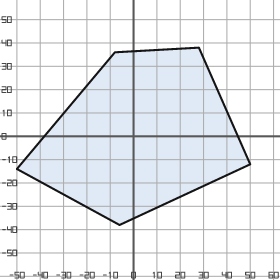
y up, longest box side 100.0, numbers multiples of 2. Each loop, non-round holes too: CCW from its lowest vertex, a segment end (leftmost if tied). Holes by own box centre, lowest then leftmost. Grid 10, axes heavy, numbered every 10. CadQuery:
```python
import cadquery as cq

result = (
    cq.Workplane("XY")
    .moveTo(-6.0, -38.0)
    .lineTo(50.0, -12.0)
    .lineTo(28.0, 38.0)
    .lineTo(-8.0, 36.0)
    .lineTo(-50.0, -14.0)
    .close()
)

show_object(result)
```